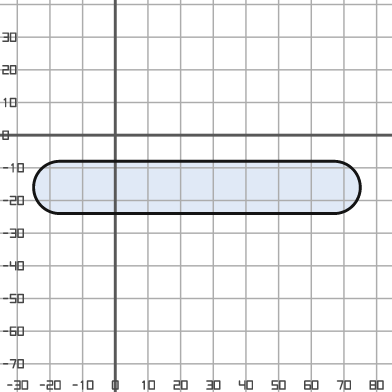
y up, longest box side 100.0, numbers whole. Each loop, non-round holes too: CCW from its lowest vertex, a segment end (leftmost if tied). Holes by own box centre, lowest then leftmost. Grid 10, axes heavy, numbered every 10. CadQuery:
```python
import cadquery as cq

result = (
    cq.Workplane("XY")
    .moveTo(-17.0, -24.0)
    .lineTo(67.0, -24.0)
    .threePointArc((75.0, -16.0), (67.0, -8.0))
    .lineTo(-17.0, -8.0)
    .threePointArc((-25.0, -16.0), (-17.0, -24.0))
    .close()
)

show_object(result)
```